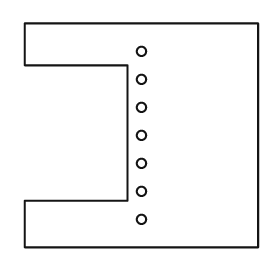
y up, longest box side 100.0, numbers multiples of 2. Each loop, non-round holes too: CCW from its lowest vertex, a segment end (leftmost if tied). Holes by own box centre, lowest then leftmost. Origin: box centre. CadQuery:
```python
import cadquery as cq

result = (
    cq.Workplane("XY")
    .moveTo(-50.0, -48.0)
    .lineTo(50.0, -48.0)
    .lineTo(50.0, 48.0)
    .lineTo(-50.0, 48.0)
    .lineTo(-50.0, 30.0)
    .lineTo(-6.0, 30.0)
    .lineTo(-6.0, -28.0)
    .lineTo(-50.0, -28.0)
    .close()
    .moveTo(0.0, -36.0)
    .circle(2.0)
    .moveTo(0.0, -24.0)
    .circle(2.0)
    .moveTo(0.0, -12.0)
    .circle(2.0)
    .moveTo(0.0, 0.0)
    .circle(2.0)
    .moveTo(0.0, 12.0)
    .circle(2.0)
    .moveTo(0.0, 24.0)
    .circle(2.0)
    .moveTo(0.0, 36.0)
    .circle(2.0)
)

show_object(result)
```